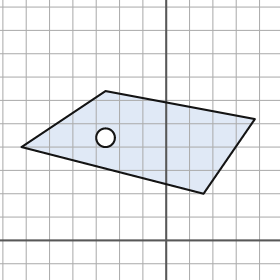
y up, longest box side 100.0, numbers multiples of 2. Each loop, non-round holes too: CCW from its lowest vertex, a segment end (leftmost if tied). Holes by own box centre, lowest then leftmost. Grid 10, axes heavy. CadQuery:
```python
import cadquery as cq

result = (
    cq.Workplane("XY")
    .moveTo(16.0, 20.0)
    .lineTo(38.0, 52.0)
    .lineTo(-26.0, 64.0)
    .lineTo(-62.0, 40.0)
    .close()
    .moveTo(-26.0, 44.0)
    .circle(4.0)
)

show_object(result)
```